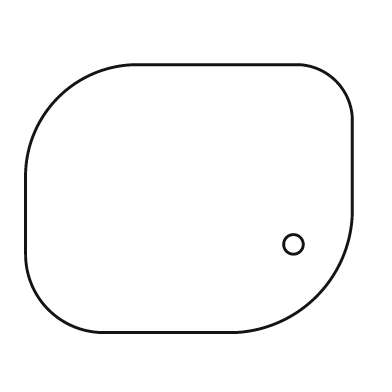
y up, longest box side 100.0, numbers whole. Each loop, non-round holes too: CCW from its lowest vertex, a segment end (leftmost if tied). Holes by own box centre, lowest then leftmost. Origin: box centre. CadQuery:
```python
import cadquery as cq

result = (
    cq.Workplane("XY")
    .moveTo(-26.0, -41.0)
    .lineTo(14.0, -41.0)
    .threePointArc((39.0, -30.0), (50.0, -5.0))
    .lineTo(50.0, 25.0)
    .threePointArc((45.0, 36.0), (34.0, 41.0))
    .lineTo(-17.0, 41.0)
    .threePointArc((-40.0, 31.0), (-50.0, 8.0))
    .lineTo(-50.0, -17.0)
    .threePointArc((-43.0, -34.0), (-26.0, -41.0))
    .close()
    .moveTo(32.0, -14.0)
    .circle(3.0)
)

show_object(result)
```